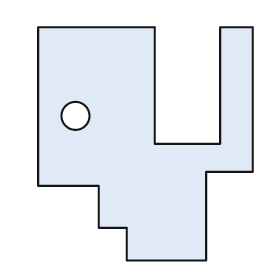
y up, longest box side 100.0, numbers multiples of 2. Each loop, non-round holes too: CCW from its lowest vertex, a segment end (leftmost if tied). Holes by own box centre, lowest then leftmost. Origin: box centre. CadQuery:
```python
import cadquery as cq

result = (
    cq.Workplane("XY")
    .moveTo(-8.0, -50.0)
    .lineTo(26.0, -50.0)
    .lineTo(26.0, -12.0)
    .lineTo(46.0, -12.0)
    .lineTo(46.0, 50.0)
    .lineTo(32.0, 50.0)
    .lineTo(32.0, 0.0)
    .lineTo(4.0, 0.0)
    .lineTo(4.0, 50.0)
    .lineTo(-46.0, 50.0)
    .lineTo(-46.0, -18.0)
    .lineTo(-20.0, -18.0)
    .lineTo(-20.0, -36.0)
    .lineTo(-8.0, -36.0)
    .close()
    .moveTo(-30.0, 12.0)
    .circle(6.0)
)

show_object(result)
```